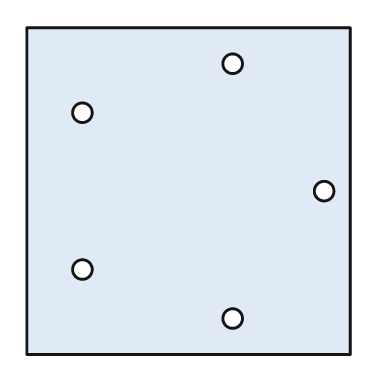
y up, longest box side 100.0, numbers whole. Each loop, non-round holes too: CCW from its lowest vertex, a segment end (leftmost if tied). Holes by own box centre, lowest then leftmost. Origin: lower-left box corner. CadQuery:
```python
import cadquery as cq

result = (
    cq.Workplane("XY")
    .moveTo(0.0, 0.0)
    .lineTo(99.0, 0.0)
    .lineTo(99.0, 100.0)
    .lineTo(0.0, 100.0)
    .close()
    .moveTo(63.0, 11.0)
    .circle(3.0)
    .moveTo(17.0, 26.0)
    .circle(3.0)
    .moveTo(91.0, 50.0)
    .circle(3.0)
    .moveTo(17.0, 74.0)
    .circle(3.0)
    .moveTo(63.0, 89.0)
    .circle(3.0)
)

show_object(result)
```